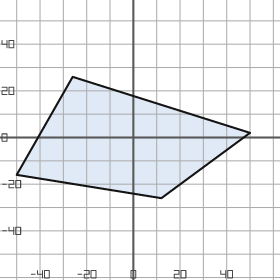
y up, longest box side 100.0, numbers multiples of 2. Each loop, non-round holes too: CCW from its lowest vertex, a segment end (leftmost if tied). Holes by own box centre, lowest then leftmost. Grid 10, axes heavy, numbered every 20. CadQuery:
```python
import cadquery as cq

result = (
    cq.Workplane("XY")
    .moveTo(12.0, -26.0)
    .lineTo(50.0, 2.0)
    .lineTo(-26.0, 26.0)
    .lineTo(-50.0, -16.0)
    .close()
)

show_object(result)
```